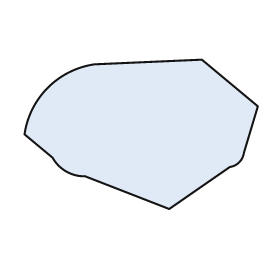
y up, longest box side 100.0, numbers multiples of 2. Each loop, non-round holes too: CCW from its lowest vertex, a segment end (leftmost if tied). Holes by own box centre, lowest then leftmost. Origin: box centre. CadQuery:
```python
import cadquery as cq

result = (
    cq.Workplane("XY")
    .moveTo(12.0, -32.0)
    .lineTo(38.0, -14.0)
    .threePointArc((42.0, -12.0), (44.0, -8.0))
    .lineTo(50.0, 12.0)
    .lineTo(26.0, 32.0)
    .lineTo(-20.0, 30.0)
    .threePointArc((-40.0, 20.0), (-50.0, 0.0))
    .lineTo(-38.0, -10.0)
    .threePointArc((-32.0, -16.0), (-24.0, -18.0))
    .close()
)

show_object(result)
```